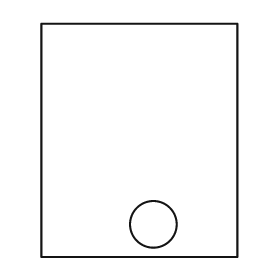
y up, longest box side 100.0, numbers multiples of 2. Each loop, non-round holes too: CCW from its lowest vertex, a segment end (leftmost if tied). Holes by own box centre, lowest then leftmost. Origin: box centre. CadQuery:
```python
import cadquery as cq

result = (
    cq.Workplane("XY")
    .moveTo(-42.0, -50.0)
    .lineTo(42.0, -50.0)
    .lineTo(42.0, 50.0)
    .lineTo(-42.0, 50.0)
    .close()
    .moveTo(6.0, -36.0)
    .circle(10.0)
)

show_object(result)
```